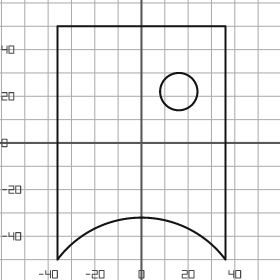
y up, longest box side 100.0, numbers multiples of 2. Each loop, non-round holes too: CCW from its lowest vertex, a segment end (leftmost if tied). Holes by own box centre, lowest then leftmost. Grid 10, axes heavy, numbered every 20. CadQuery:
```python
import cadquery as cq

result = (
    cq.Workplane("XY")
    .moveTo(-36.0, -50.0)
    .threePointArc((0.0, -32.0), (36.0, -50.0))
    .lineTo(36.0, 50.0)
    .lineTo(-36.0, 50.0)
    .close()
    .moveTo(16.0, 22.0)
    .circle(8.0)
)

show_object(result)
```